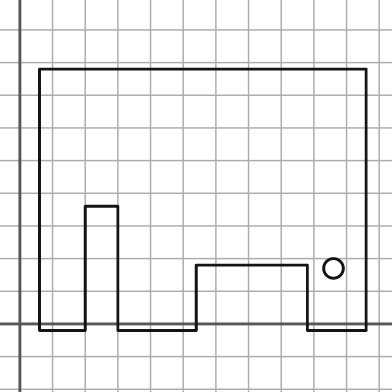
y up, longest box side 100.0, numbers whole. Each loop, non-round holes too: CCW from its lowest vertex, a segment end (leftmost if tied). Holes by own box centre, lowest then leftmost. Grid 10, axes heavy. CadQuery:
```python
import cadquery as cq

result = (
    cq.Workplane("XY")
    .moveTo(6.0, -2.0)
    .lineTo(20.0, -2.0)
    .lineTo(20.0, 36.0)
    .lineTo(30.0, 36.0)
    .lineTo(30.0, -2.0)
    .lineTo(54.0, -2.0)
    .lineTo(54.0, 18.0)
    .lineTo(88.0, 18.0)
    .lineTo(88.0, -2.0)
    .lineTo(106.0, -2.0)
    .lineTo(106.0, 78.0)
    .lineTo(6.0, 78.0)
    .close()
    .moveTo(96.0, 17.0)
    .circle(3.0)
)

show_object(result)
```